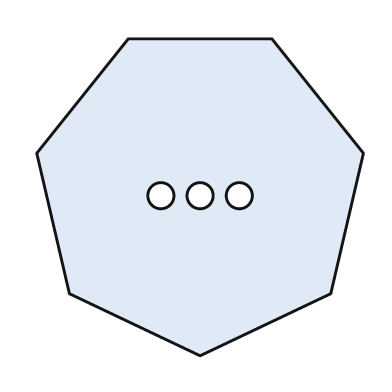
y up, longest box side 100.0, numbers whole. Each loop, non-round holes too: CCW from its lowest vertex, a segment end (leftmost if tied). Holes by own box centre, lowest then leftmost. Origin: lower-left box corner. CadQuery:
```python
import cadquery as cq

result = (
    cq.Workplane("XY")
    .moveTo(50.0, 0.0)
    .lineTo(90.0, 19.0)
    .lineTo(100.0, 62.0)
    .lineTo(72.0, 97.0)
    .lineTo(28.0, 97.0)
    .lineTo(0.0, 62.0)
    .lineTo(10.0, 19.0)
    .close()
    .moveTo(38.0, 49.0)
    .circle(4.0)
    .moveTo(50.0, 49.0)
    .circle(4.0)
    .moveTo(62.0, 49.0)
    .circle(4.0)
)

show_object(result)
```